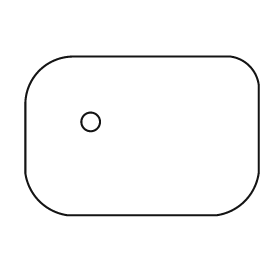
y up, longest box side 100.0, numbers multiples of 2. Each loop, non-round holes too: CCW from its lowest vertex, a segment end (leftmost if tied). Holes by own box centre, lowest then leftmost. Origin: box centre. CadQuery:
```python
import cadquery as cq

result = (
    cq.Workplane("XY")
    .moveTo(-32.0, -34.0)
    .lineTo(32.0, -34.0)
    .threePointArc((44.0, -28.0), (50.0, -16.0))
    .lineTo(50.0, 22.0)
    .threePointArc((46.0, 30.0), (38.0, 34.0))
    .lineTo(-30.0, 34.0)
    .threePointArc((-44.0, 28.0), (-50.0, 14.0))
    .lineTo(-50.0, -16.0)
    .threePointArc((-44.0, -28.0), (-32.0, -34.0))
    .close()
    .moveTo(-22.0, 6.0)
    .circle(4.0)
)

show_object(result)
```